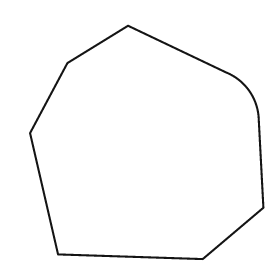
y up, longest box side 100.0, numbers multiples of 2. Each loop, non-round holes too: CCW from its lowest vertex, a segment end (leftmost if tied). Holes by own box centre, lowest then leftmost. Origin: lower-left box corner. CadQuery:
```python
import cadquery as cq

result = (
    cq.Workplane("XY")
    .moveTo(74.0, 0.0)
    .lineTo(100.0, 22.0)
    .lineTo(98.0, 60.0)
    .threePointArc((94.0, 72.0), (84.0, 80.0))
    .lineTo(42.0, 100.0)
    .lineTo(16.0, 84.0)
    .lineTo(0.0, 54.0)
    .lineTo(12.0, 2.0)
    .close()
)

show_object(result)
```